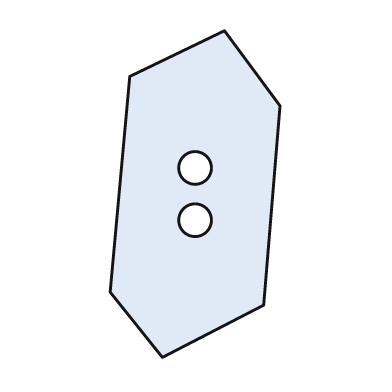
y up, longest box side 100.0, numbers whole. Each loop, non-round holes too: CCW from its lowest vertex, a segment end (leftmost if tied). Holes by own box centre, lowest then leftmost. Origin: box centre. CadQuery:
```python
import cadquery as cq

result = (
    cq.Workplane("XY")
    .moveTo(-10.0, -50.0)
    .lineTo(21.0, -34.0)
    .lineTo(26.0, 27.0)
    .lineTo(9.0, 50.0)
    .lineTo(-20.0, 36.0)
    .lineTo(-26.0, -30.0)
    .close()
    .moveTo(0.0, -8.0)
    .circle(5.0)
    .moveTo(0.0, 8.0)
    .circle(5.0)
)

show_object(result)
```